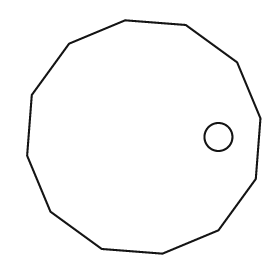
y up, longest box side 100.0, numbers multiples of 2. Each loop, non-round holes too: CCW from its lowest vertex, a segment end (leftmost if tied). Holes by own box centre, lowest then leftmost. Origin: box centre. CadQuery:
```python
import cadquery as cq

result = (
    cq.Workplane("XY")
    .moveTo(8.0, -50.0)
    .lineTo(32.0, -40.0)
    .lineTo(48.0, -18.0)
    .lineTo(50.0, 8.0)
    .lineTo(40.0, 32.0)
    .lineTo(18.0, 48.0)
    .lineTo(-8.0, 50.0)
    .lineTo(-32.0, 40.0)
    .lineTo(-48.0, 18.0)
    .lineTo(-50.0, -8.0)
    .lineTo(-40.0, -32.0)
    .lineTo(-18.0, -48.0)
    .close()
    .moveTo(32.0, 0.0)
    .circle(6.0)
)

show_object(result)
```